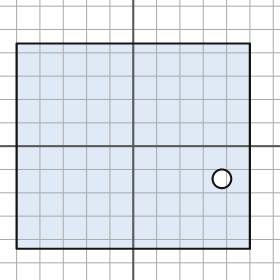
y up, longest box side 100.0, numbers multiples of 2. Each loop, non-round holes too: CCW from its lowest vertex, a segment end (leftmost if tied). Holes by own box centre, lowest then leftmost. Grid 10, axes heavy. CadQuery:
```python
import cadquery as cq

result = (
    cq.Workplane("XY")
    .moveTo(-50.0, -44.0)
    .lineTo(50.0, -44.0)
    .lineTo(50.0, 44.0)
    .lineTo(-50.0, 44.0)
    .close()
    .moveTo(38.0, -14.0)
    .circle(4.0)
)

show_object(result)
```